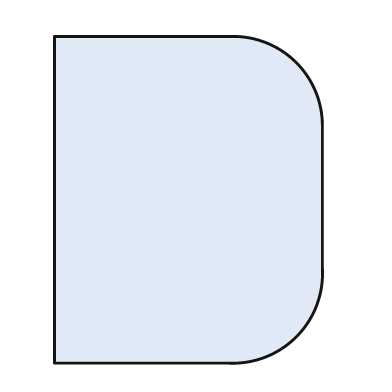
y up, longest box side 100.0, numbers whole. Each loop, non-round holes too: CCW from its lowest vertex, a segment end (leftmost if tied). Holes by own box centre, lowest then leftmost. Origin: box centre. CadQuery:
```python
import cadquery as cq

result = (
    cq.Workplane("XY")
    .moveTo(-41.0, -50.0)
    .lineTo(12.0, -50.0)
    .threePointArc((33.0, -42.0), (41.0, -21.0))
    .lineTo(41.0, 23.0)
    .threePointArc((33.0, 42.0), (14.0, 50.0))
    .lineTo(-41.0, 50.0)
    .close()
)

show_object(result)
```